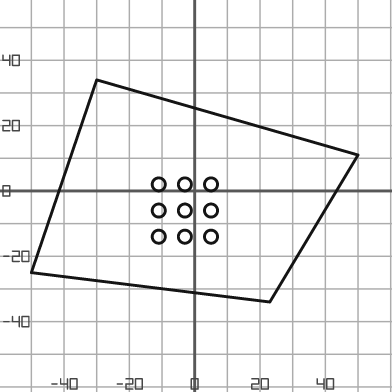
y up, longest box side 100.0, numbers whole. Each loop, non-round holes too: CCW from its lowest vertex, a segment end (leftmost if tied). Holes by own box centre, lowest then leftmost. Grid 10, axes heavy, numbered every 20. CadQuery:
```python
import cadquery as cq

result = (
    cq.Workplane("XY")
    .moveTo(23.0, -34.0)
    .lineTo(50.0, 11.0)
    .lineTo(-30.0, 34.0)
    .lineTo(-50.0, -25.0)
    .close()
    .moveTo(-11.0, -14.0)
    .circle(2.0)
    .moveTo(-3.0, -14.0)
    .circle(2.0)
    .moveTo(5.0, -14.0)
    .circle(2.0)
    .moveTo(-11.0, -6.0)
    .circle(2.0)
    .moveTo(-3.0, -6.0)
    .circle(2.0)
    .moveTo(5.0, -6.0)
    .circle(2.0)
    .moveTo(-11.0, 2.0)
    .circle(2.0)
    .moveTo(-3.0, 2.0)
    .circle(2.0)
    .moveTo(5.0, 2.0)
    .circle(2.0)
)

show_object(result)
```